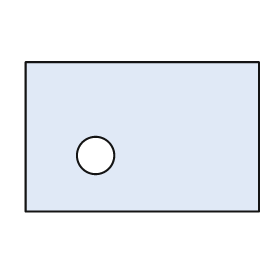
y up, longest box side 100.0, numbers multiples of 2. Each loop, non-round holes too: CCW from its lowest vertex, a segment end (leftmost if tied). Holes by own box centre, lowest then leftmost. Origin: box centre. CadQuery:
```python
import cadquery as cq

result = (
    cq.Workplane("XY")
    .moveTo(-50.0, -32.0)
    .lineTo(50.0, -32.0)
    .lineTo(50.0, 32.0)
    .lineTo(-50.0, 32.0)
    .close()
    .moveTo(-20.0, -8.0)
    .circle(8.0)
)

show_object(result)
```